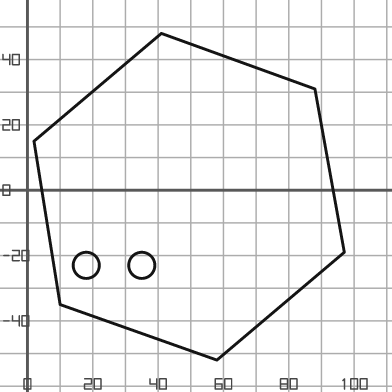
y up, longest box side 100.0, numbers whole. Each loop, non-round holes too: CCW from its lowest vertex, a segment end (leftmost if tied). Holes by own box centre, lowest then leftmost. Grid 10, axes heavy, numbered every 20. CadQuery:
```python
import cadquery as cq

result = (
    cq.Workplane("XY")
    .moveTo(58.0, -52.0)
    .lineTo(97.0, -19.0)
    .lineTo(88.0, 31.0)
    .lineTo(41.0, 48.0)
    .lineTo(2.0, 15.0)
    .lineTo(10.0, -35.0)
    .close()
    .moveTo(18.0, -23.0)
    .circle(4.0)
    .moveTo(35.0, -23.0)
    .circle(4.0)
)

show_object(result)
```